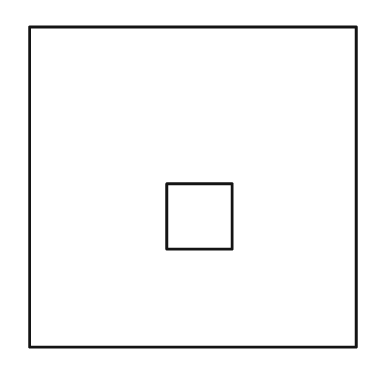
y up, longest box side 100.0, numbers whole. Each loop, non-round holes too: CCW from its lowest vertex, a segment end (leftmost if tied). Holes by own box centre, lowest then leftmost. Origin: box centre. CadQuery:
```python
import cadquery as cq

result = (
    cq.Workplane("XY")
    .moveTo(-50.0, -49.0)
    .lineTo(50.0, -49.0)
    .lineTo(50.0, 49.0)
    .lineTo(-50.0, 49.0)
    .close()
    .moveTo(-8.0, -19.0)
    .lineTo(12.0, -19.0)
    .lineTo(12.0, 1.0)
    .lineTo(-8.0, 1.0)
    .close()
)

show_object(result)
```